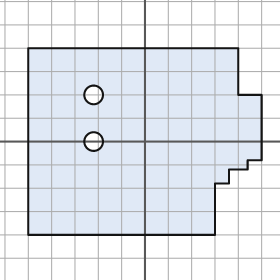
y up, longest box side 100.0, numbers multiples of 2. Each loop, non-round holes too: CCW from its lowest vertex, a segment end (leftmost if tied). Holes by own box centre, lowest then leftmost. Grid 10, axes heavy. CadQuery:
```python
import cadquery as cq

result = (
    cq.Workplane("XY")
    .moveTo(-50.0, -40.0)
    .lineTo(30.0, -40.0)
    .lineTo(30.0, -18.0)
    .lineTo(36.0, -18.0)
    .lineTo(36.0, -12.0)
    .lineTo(44.0, -12.0)
    .lineTo(44.0, -8.0)
    .lineTo(50.0, -8.0)
    .lineTo(50.0, 20.0)
    .lineTo(40.0, 20.0)
    .lineTo(40.0, 40.0)
    .lineTo(-50.0, 40.0)
    .close()
    .moveTo(-22.0, 0.0)
    .circle(4.0)
    .moveTo(-22.0, 20.0)
    .circle(4.0)
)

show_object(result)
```